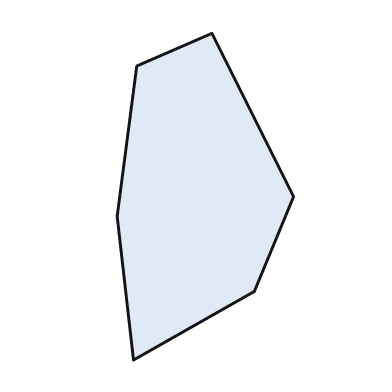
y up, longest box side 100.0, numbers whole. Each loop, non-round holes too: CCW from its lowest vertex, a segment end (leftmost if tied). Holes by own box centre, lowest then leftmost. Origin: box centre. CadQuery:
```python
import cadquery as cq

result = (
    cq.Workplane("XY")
    .moveTo(-22.0, -50.0)
    .lineTo(15.0, -29.0)
    .lineTo(27.0, 0.0)
    .lineTo(2.0, 50.0)
    .lineTo(-21.0, 40.0)
    .lineTo(-27.0, -6.0)
    .close()
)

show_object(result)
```